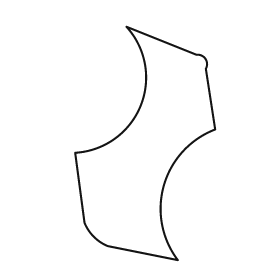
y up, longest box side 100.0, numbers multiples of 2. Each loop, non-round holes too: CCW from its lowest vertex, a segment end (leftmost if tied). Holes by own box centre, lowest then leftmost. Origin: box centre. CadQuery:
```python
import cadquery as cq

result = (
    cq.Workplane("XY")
    .moveTo(14.0, -50.0)
    .threePointArc((8.0, -18.0), (30.0, 6.0))
    .lineTo(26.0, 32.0)
    .threePointArc((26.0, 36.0), (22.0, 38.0))
    .lineTo(-8.0, 50.0)
    .threePointArc((-2.0, 16.0), (-30.0, -4.0))
    .lineTo(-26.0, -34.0)
    .threePointArc((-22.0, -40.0), (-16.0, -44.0))
    .close()
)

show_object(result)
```